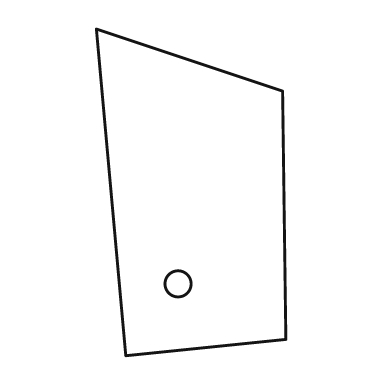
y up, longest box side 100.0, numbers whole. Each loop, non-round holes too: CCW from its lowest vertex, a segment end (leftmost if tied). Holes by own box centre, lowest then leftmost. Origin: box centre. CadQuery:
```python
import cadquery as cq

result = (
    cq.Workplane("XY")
    .moveTo(-20.0, -50.0)
    .lineTo(29.0, -45.0)
    .lineTo(28.0, 31.0)
    .lineTo(-29.0, 50.0)
    .close()
    .moveTo(-4.0, -28.0)
    .circle(4.0)
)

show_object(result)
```